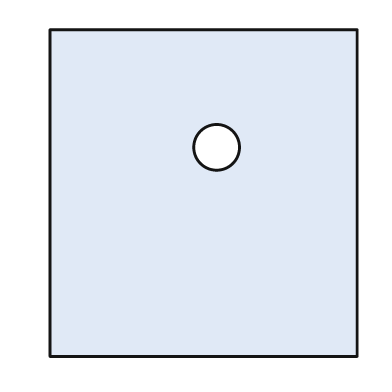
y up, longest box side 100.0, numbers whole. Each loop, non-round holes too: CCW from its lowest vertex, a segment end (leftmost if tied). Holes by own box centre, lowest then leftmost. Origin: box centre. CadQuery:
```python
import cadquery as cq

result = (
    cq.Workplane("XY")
    .moveTo(-47.0, -50.0)
    .lineTo(47.0, -50.0)
    .lineTo(47.0, 50.0)
    .lineTo(-47.0, 50.0)
    .close()
    .moveTo(4.0, 14.0)
    .circle(7.0)
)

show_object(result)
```